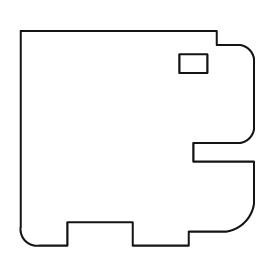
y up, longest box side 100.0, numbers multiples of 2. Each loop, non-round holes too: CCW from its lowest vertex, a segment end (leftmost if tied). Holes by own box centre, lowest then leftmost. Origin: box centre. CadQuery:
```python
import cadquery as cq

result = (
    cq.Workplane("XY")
    .moveTo(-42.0, -46.0)
    .lineTo(-30.0, -46.0)
    .lineTo(-30.0, -36.0)
    .lineTo(-2.0, -36.0)
    .lineTo(-2.0, -46.0)
    .lineTo(22.0, -46.0)
    .lineTo(22.0, -40.0)
    .lineTo(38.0, -40.0)
    .threePointArc((46.0, -36.0), (50.0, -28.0))
    .lineTo(50.0, -10.0)
    .lineTo(24.0, -10.0)
    .lineTo(24.0, -2.0)
    .lineTo(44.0, -2.0)
    .threePointArc((48.0, 0.0), (50.0, 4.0))
    .lineTo(50.0, 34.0)
    .threePointArc((48.0, 38.0), (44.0, 40.0))
    .lineTo(34.0, 40.0)
    .lineTo(34.0, 46.0)
    .lineTo(-50.0, 46.0)
    .lineTo(-50.0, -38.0)
    .threePointArc((-48.0, -44.0), (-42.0, -46.0))
    .close()
    .moveTo(18.0, 28.0)
    .lineTo(30.0, 28.0)
    .lineTo(30.0, 36.0)
    .lineTo(18.0, 36.0)
    .close()
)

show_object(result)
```